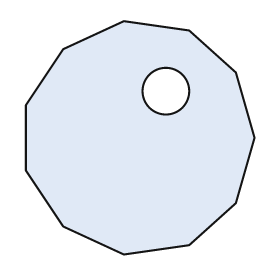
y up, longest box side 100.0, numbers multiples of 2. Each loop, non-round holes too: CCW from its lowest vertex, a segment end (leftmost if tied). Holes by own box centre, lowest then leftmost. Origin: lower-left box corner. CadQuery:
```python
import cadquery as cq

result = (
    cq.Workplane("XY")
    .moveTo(42.0, 0.0)
    .lineTo(70.0, 4.0)
    .lineTo(90.0, 22.0)
    .lineTo(98.0, 50.0)
    .lineTo(90.0, 78.0)
    .lineTo(70.0, 96.0)
    .lineTo(42.0, 100.0)
    .lineTo(16.0, 88.0)
    .lineTo(0.0, 64.0)
    .lineTo(0.0, 36.0)
    .lineTo(16.0, 12.0)
    .close()
    .moveTo(60.0, 70.0)
    .circle(10.0)
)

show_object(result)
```